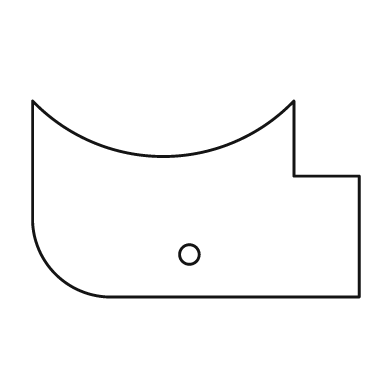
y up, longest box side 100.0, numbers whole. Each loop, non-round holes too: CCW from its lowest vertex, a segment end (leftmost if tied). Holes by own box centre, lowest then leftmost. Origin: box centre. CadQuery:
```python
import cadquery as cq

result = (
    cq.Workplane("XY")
    .moveTo(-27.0, -30.0)
    .lineTo(50.0, -30.0)
    .lineTo(50.0, 7.0)
    .lineTo(30.0, 7.0)
    .lineTo(30.0, 30.0)
    .threePointArc((-10.0, 13.0), (-50.0, 30.0))
    .lineTo(-50.0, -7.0)
    .threePointArc((-43.0, -23.0), (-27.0, -30.0))
    .close()
    .moveTo(-2.0, -17.0)
    .circle(3.0)
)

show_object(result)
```